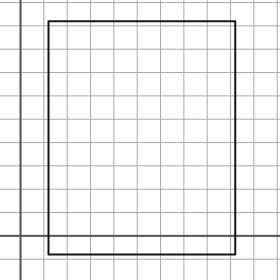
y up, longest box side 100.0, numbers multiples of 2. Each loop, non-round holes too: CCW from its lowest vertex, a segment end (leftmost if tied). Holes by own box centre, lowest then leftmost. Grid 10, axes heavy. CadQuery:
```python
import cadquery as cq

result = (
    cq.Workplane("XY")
    .moveTo(12.0, -8.0)
    .lineTo(92.0, -8.0)
    .lineTo(92.0, 92.0)
    .lineTo(12.0, 92.0)
    .close()
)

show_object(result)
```